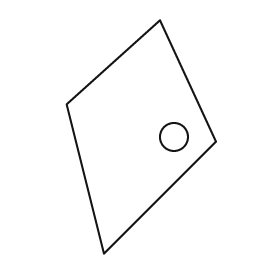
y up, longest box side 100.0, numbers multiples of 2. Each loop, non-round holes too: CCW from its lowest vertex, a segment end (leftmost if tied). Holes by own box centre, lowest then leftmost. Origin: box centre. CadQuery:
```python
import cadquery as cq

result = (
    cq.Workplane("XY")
    .moveTo(-16.0, -50.0)
    .lineTo(32.0, -2.0)
    .lineTo(8.0, 50.0)
    .lineTo(-32.0, 14.0)
    .close()
    .moveTo(14.0, 0.0)
    .circle(6.0)
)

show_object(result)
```